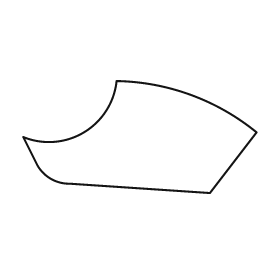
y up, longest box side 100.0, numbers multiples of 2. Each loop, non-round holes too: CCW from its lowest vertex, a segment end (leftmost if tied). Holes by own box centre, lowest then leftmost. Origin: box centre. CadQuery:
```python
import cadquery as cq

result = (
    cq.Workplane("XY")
    .moveTo(30.0, -24.0)
    .lineTo(50.0, 2.0)
    .threePointArc((22.0, 18.0), (-10.0, 24.0))
    .threePointArc((-24.0, 2.0), (-50.0, 0.0))
    .lineTo(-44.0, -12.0)
    .threePointArc((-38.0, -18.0), (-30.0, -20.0))
    .close()
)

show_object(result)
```